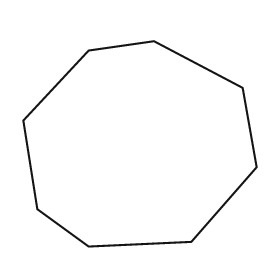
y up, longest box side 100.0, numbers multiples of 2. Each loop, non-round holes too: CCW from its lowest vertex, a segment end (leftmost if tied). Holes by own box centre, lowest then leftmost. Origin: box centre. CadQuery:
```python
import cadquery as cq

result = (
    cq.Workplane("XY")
    .moveTo(-22.0, -44.0)
    .lineTo(22.0, -42.0)
    .lineTo(50.0, -10.0)
    .lineTo(44.0, 24.0)
    .lineTo(6.0, 44.0)
    .lineTo(-22.0, 40.0)
    .lineTo(-50.0, 10.0)
    .lineTo(-44.0, -28.0)
    .close()
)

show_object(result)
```